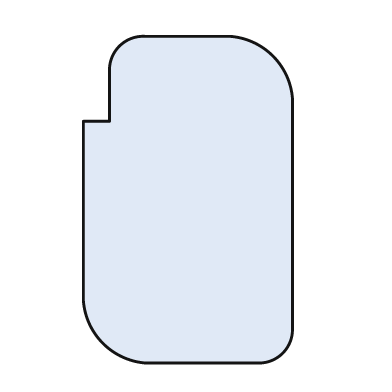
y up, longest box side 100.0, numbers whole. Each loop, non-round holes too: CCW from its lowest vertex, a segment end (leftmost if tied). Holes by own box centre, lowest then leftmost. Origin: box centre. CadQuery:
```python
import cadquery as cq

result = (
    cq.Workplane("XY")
    .moveTo(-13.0, -50.0)
    .lineTo(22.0, -50.0)
    .threePointArc((29.0, -47.0), (32.0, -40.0))
    .lineTo(32.0, 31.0)
    .threePointArc((26.0, 44.0), (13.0, 50.0))
    .lineTo(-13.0, 50.0)
    .threePointArc((-21.0, 47.0), (-24.0, 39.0))
    .lineTo(-24.0, 24.0)
    .lineTo(-32.0, 24.0)
    .lineTo(-32.0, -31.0)
    .threePointArc((-26.0, -44.0), (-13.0, -50.0))
    .close()
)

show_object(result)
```